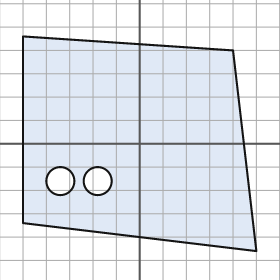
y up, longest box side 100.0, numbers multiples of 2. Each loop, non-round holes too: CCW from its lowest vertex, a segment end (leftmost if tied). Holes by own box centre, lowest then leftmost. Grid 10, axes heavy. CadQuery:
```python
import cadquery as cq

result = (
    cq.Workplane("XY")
    .moveTo(50.0, -46.0)
    .lineTo(40.0, 40.0)
    .lineTo(-50.0, 46.0)
    .lineTo(-50.0, -34.0)
    .close()
    .moveTo(-34.0, -16.0)
    .circle(6.0)
    .moveTo(-18.0, -16.0)
    .circle(6.0)
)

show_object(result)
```